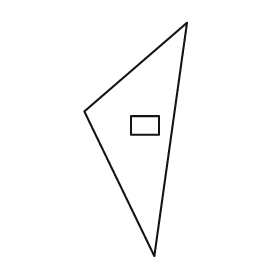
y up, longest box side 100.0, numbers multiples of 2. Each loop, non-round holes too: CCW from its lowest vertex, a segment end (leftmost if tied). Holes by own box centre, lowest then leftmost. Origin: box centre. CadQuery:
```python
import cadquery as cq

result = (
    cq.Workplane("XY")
    .moveTo(8.0, -50.0)
    .lineTo(22.0, 50.0)
    .lineTo(-22.0, 12.0)
    .close()
    .moveTo(-2.0, 2.0)
    .lineTo(10.0, 2.0)
    .lineTo(10.0, 10.0)
    .lineTo(-2.0, 10.0)
    .close()
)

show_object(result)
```